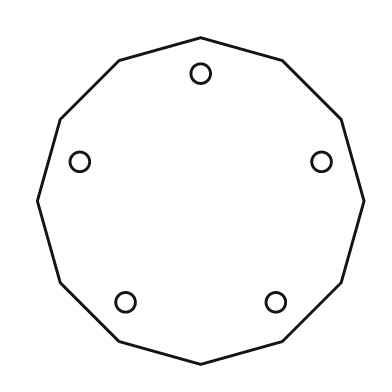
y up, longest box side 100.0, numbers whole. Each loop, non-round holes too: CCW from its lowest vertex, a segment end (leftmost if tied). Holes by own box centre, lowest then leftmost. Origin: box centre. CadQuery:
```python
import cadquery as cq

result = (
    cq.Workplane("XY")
    .moveTo(0.0, -50.0)
    .lineTo(25.0, -43.0)
    .lineTo(43.0, -25.0)
    .lineTo(50.0, 0.0)
    .lineTo(43.0, 25.0)
    .lineTo(25.0, 43.0)
    .lineTo(0.0, 50.0)
    .lineTo(-25.0, 43.0)
    .lineTo(-43.0, 25.0)
    .lineTo(-50.0, 0.0)
    .lineTo(-43.0, -25.0)
    .lineTo(-25.0, -43.0)
    .close()
    .moveTo(-23.0, -31.0)
    .circle(3.0)
    .moveTo(23.0, -31.0)
    .circle(3.0)
    .moveTo(-37.0, 12.0)
    .circle(3.0)
    .moveTo(37.0, 12.0)
    .circle(3.0)
    .moveTo(0.0, 39.0)
    .circle(3.0)
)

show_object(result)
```